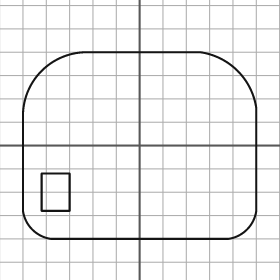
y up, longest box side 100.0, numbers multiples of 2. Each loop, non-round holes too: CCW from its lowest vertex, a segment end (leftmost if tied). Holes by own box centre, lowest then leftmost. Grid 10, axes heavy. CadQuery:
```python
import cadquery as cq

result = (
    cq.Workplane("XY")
    .moveTo(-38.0, -40.0)
    .lineTo(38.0, -40.0)
    .threePointArc((46.0, -36.0), (50.0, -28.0))
    .lineTo(50.0, 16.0)
    .threePointArc((42.0, 32.0), (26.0, 40.0))
    .lineTo(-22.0, 40.0)
    .threePointArc((-42.0, 32.0), (-50.0, 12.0))
    .lineTo(-50.0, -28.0)
    .threePointArc((-46.0, -36.0), (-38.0, -40.0))
    .close()
    .moveTo(-42.0, -28.0)
    .lineTo(-30.0, -28.0)
    .lineTo(-30.0, -12.0)
    .lineTo(-42.0, -12.0)
    .close()
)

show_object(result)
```